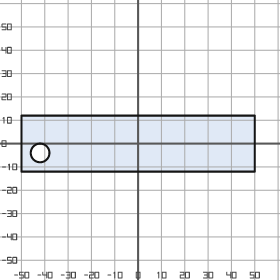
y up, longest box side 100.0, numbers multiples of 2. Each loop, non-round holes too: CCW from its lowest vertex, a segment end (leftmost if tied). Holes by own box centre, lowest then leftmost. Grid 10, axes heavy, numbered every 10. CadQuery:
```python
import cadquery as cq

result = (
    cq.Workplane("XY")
    .moveTo(-50.0, -12.0)
    .lineTo(50.0, -12.0)
    .lineTo(50.0, 12.0)
    .lineTo(-50.0, 12.0)
    .close()
    .moveTo(-42.0, -4.0)
    .circle(4.0)
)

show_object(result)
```